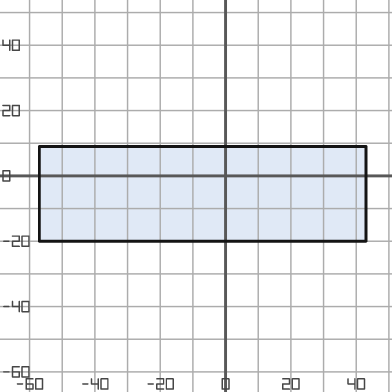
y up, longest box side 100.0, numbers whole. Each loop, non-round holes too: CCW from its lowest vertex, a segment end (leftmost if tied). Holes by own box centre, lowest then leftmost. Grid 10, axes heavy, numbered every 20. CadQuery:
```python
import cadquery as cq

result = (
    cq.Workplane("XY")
    .moveTo(-57.0, -20.0)
    .lineTo(43.0, -20.0)
    .lineTo(43.0, 9.0)
    .lineTo(-57.0, 9.0)
    .close()
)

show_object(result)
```